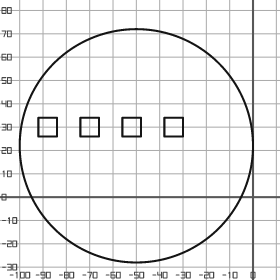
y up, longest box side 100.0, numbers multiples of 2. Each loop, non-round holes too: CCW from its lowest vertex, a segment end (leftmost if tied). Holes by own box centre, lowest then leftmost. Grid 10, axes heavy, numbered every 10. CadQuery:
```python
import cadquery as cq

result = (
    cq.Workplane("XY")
    .moveTo(-50.0, 22.0)
    .circle(50.0)
    .moveTo(-92.0, 26.0)
    .lineTo(-84.0, 26.0)
    .lineTo(-84.0, 34.0)
    .lineTo(-92.0, 34.0)
    .close()
    .moveTo(-74.0, 26.0)
    .lineTo(-66.0, 26.0)
    .lineTo(-66.0, 34.0)
    .lineTo(-74.0, 34.0)
    .close()
    .moveTo(-56.0, 26.0)
    .lineTo(-48.0, 26.0)
    .lineTo(-48.0, 34.0)
    .lineTo(-56.0, 34.0)
    .close()
    .moveTo(-38.0, 26.0)
    .lineTo(-30.0, 26.0)
    .lineTo(-30.0, 34.0)
    .lineTo(-38.0, 34.0)
    .close()
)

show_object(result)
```